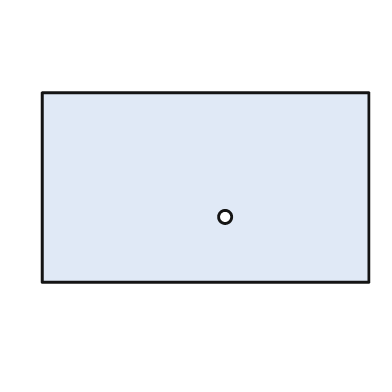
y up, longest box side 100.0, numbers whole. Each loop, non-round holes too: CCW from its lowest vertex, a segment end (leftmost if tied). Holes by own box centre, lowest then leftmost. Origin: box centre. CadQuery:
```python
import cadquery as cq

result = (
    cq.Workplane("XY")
    .moveTo(-50.0, -29.0)
    .lineTo(50.0, -29.0)
    .lineTo(50.0, 29.0)
    .lineTo(-50.0, 29.0)
    .close()
    .moveTo(6.0, -9.0)
    .circle(2.0)
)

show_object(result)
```